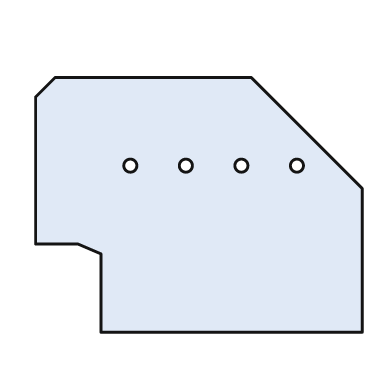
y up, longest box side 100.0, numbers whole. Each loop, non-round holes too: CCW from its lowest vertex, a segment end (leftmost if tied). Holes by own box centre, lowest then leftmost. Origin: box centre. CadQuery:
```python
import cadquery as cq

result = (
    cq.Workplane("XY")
    .moveTo(-30.0, -39.0)
    .lineTo(50.0, -39.0)
    .lineTo(50.0, 5.0)
    .lineTo(16.0, 39.0)
    .lineTo(-44.0, 39.0)
    .lineTo(-50.0, 33.0)
    .lineTo(-50.0, -12.0)
    .lineTo(-37.0, -12.0)
    .lineTo(-30.0, -15.0)
    .close()
    .moveTo(-21.0, 12.0)
    .circle(2.0)
    .moveTo(-4.0, 12.0)
    .circle(2.0)
    .moveTo(13.0, 12.0)
    .circle(2.0)
    .moveTo(30.0, 12.0)
    .circle(2.0)
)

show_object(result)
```